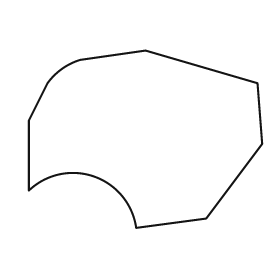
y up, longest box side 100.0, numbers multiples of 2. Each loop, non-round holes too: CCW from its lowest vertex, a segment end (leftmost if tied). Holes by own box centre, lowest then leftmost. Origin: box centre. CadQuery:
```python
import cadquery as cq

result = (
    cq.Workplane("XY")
    .moveTo(-4.0, -38.0)
    .lineTo(26.0, -34.0)
    .lineTo(50.0, -2.0)
    .lineTo(48.0, 24.0)
    .lineTo(0.0, 38.0)
    .lineTo(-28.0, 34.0)
    .threePointArc((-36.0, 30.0), (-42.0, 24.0))
    .lineTo(-50.0, 8.0)
    .lineTo(-50.0, -22.0)
    .threePointArc((-22.0, -16.0), (-4.0, -38.0))
    .close()
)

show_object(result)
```